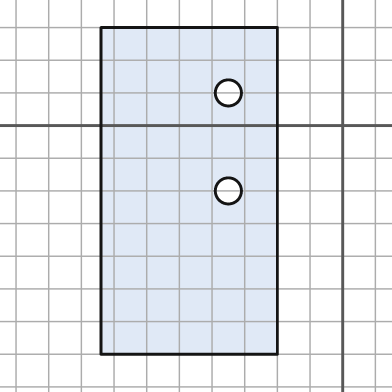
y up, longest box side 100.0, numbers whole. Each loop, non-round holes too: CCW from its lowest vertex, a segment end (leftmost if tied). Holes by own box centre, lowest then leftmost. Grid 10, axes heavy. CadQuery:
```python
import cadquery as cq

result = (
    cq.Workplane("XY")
    .moveTo(-74.0, -70.0)
    .lineTo(-20.0, -70.0)
    .lineTo(-20.0, 30.0)
    .lineTo(-74.0, 30.0)
    .close()
    .moveTo(-35.0, -20.0)
    .circle(4.0)
    .moveTo(-35.0, 10.0)
    .circle(4.0)
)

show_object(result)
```